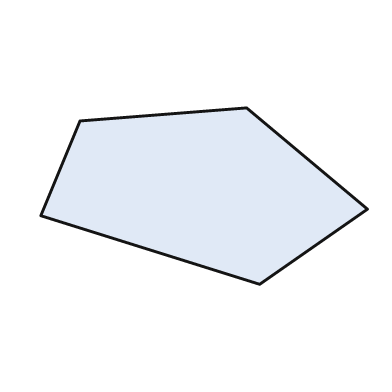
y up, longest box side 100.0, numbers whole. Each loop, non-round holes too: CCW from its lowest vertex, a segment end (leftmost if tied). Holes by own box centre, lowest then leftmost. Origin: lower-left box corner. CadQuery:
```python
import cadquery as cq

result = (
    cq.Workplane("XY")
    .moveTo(67.0, 0.0)
    .lineTo(100.0, 23.0)
    .lineTo(63.0, 54.0)
    .lineTo(12.0, 50.0)
    .lineTo(0.0, 21.0)
    .close()
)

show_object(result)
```